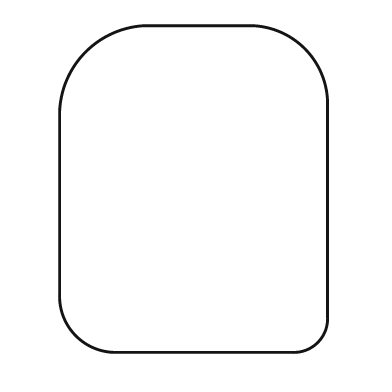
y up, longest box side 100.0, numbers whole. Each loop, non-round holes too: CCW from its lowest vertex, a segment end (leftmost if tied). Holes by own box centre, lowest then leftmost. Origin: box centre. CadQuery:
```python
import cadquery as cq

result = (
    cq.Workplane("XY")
    .moveTo(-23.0, -50.0)
    .lineTo(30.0, -50.0)
    .threePointArc((38.0, -47.0), (41.0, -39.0))
    .lineTo(41.0, 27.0)
    .threePointArc((34.0, 43.0), (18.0, 50.0))
    .lineTo(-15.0, 50.0)
    .threePointArc((-33.0, 42.0), (-41.0, 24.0))
    .lineTo(-41.0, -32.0)
    .threePointArc((-36.0, -45.0), (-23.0, -50.0))
    .close()
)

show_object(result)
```